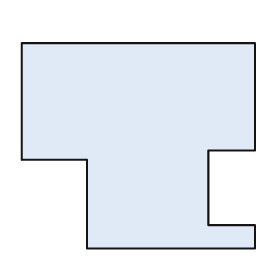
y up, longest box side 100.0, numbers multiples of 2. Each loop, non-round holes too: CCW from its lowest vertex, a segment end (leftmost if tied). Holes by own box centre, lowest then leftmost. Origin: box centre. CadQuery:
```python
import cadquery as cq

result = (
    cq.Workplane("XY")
    .moveTo(-22.0, -44.0)
    .lineTo(50.0, -44.0)
    .lineTo(50.0, -34.0)
    .lineTo(30.0, -34.0)
    .lineTo(30.0, -2.0)
    .lineTo(50.0, -2.0)
    .lineTo(50.0, 44.0)
    .lineTo(-50.0, 44.0)
    .lineTo(-50.0, -6.0)
    .lineTo(-22.0, -6.0)
    .close()
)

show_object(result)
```